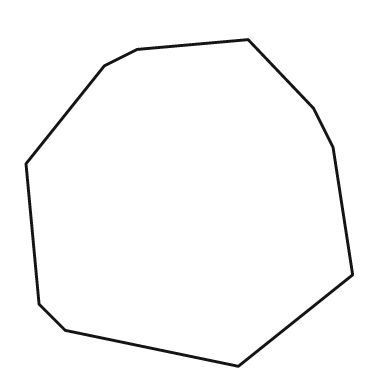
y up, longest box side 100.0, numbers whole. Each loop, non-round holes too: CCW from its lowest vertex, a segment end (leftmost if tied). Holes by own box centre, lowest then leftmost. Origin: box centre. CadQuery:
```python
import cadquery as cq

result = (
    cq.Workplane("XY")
    .moveTo(15.0, -50.0)
    .lineTo(50.0, -22.0)
    .lineTo(44.0, 17.0)
    .lineTo(38.0, 29.0)
    .lineTo(18.0, 50.0)
    .lineTo(-16.0, 47.0)
    .lineTo(-26.0, 42.0)
    .lineTo(-50.0, 12.0)
    .lineTo(-46.0, -31.0)
    .lineTo(-38.0, -39.0)
    .close()
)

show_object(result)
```